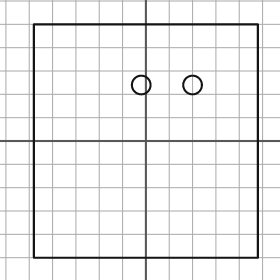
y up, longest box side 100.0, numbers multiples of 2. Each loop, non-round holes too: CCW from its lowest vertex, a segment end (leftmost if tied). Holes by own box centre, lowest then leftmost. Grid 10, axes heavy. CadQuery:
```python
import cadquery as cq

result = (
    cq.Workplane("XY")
    .moveTo(-48.0, -50.0)
    .lineTo(48.0, -50.0)
    .lineTo(48.0, 50.0)
    .lineTo(-48.0, 50.0)
    .close()
    .moveTo(-2.0, 24.0)
    .circle(4.0)
    .moveTo(20.0, 24.0)
    .circle(4.0)
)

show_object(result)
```